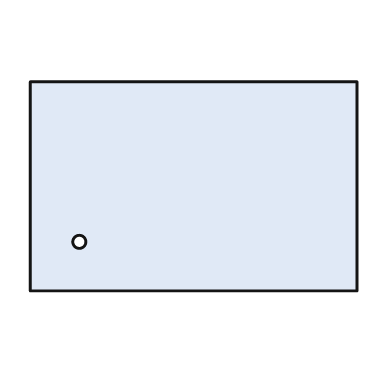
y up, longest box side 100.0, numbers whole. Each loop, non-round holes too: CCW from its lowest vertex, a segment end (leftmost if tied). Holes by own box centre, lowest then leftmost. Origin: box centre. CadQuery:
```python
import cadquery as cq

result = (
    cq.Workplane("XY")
    .moveTo(-50.0, -32.0)
    .lineTo(50.0, -32.0)
    .lineTo(50.0, 32.0)
    .lineTo(-50.0, 32.0)
    .close()
    .moveTo(-35.0, -17.0)
    .circle(2.0)
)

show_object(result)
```